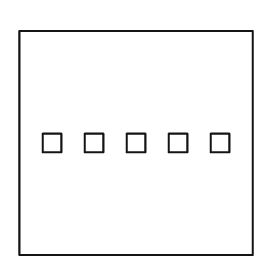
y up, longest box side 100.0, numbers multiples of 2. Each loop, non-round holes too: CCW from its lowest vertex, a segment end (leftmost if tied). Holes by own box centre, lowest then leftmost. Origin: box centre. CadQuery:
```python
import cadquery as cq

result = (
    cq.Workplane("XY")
    .moveTo(-50.0, -48.0)
    .lineTo(50.0, -48.0)
    .lineTo(50.0, 48.0)
    .lineTo(-50.0, 48.0)
    .close()
    .moveTo(-40.0, -4.0)
    .lineTo(-32.0, -4.0)
    .lineTo(-32.0, 4.0)
    .lineTo(-40.0, 4.0)
    .close()
    .moveTo(-22.0, -4.0)
    .lineTo(-14.0, -4.0)
    .lineTo(-14.0, 4.0)
    .lineTo(-22.0, 4.0)
    .close()
    .moveTo(-4.0, -4.0)
    .lineTo(4.0, -4.0)
    .lineTo(4.0, 4.0)
    .lineTo(-4.0, 4.0)
    .close()
    .moveTo(14.0, -4.0)
    .lineTo(22.0, -4.0)
    .lineTo(22.0, 4.0)
    .lineTo(14.0, 4.0)
    .close()
    .moveTo(32.0, -4.0)
    .lineTo(40.0, -4.0)
    .lineTo(40.0, 4.0)
    .lineTo(32.0, 4.0)
    .close()
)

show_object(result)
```